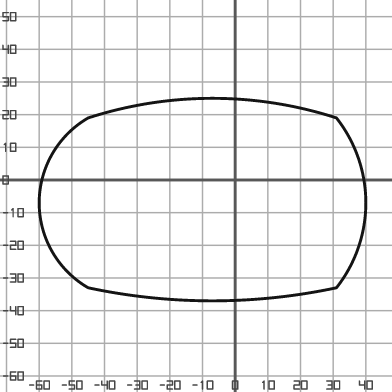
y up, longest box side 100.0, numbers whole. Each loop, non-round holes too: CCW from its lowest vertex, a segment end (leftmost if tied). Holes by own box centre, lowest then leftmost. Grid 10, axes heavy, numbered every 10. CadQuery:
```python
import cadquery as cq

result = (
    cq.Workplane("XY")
    .moveTo(-45.0, -33.0)
    .threePointArc((-7.0, -37.0), (31.0, -33.0))
    .threePointArc((40.0, -7.0), (31.0, 19.0))
    .threePointArc((-7.0, 25.0), (-45.0, 19.0))
    .threePointArc((-60.0, -7.0), (-45.0, -33.0))
    .close()
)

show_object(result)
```